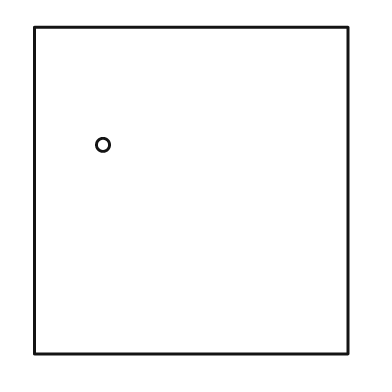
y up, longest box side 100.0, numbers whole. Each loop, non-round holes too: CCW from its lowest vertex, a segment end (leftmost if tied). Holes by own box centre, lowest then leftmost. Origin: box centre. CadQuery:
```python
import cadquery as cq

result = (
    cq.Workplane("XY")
    .moveTo(-48.0, -50.0)
    .lineTo(48.0, -50.0)
    .lineTo(48.0, 50.0)
    .lineTo(-48.0, 50.0)
    .close()
    .moveTo(-27.0, 14.0)
    .circle(2.0)
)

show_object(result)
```